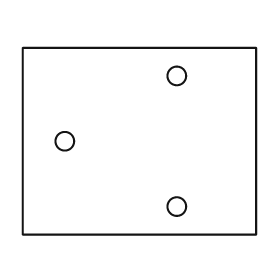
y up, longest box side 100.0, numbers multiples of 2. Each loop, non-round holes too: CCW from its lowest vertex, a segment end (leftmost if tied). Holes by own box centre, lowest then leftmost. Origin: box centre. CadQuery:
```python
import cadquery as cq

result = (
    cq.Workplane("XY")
    .moveTo(-50.0, -40.0)
    .lineTo(50.0, -40.0)
    .lineTo(50.0, 40.0)
    .lineTo(-50.0, 40.0)
    .close()
    .moveTo(16.0, -28.0)
    .circle(4.0)
    .moveTo(-32.0, 0.0)
    .circle(4.0)
    .moveTo(16.0, 28.0)
    .circle(4.0)
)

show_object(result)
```